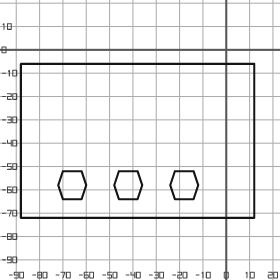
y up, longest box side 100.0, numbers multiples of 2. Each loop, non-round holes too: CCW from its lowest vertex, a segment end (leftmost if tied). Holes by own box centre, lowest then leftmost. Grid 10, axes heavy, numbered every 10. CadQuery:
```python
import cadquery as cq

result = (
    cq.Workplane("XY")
    .moveTo(-88.0, -72.0)
    .lineTo(12.0, -72.0)
    .lineTo(12.0, -6.0)
    .lineTo(-88.0, -6.0)
    .close()
    .moveTo(-70.0, -64.0)
    .lineTo(-62.0, -64.0)
    .lineTo(-60.0, -58.0)
    .lineTo(-62.0, -52.0)
    .lineTo(-70.0, -52.0)
    .lineTo(-72.0, -58.0)
    .close()
    .moveTo(-46.0, -64.0)
    .lineTo(-38.0, -64.0)
    .lineTo(-36.0, -58.0)
    .lineTo(-38.0, -52.0)
    .lineTo(-46.0, -52.0)
    .lineTo(-48.0, -58.0)
    .close()
    .moveTo(-22.0, -64.0)
    .lineTo(-14.0, -64.0)
    .lineTo(-12.0, -58.0)
    .lineTo(-14.0, -52.0)
    .lineTo(-22.0, -52.0)
    .lineTo(-24.0, -58.0)
    .close()
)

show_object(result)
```